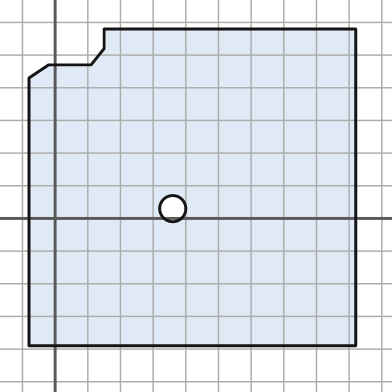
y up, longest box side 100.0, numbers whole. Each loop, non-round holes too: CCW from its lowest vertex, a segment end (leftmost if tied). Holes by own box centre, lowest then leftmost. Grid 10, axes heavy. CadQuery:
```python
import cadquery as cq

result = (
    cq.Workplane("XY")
    .moveTo(-8.0, -39.0)
    .lineTo(92.0, -39.0)
    .lineTo(92.0, 58.0)
    .lineTo(15.0, 58.0)
    .lineTo(15.0, 52.0)
    .lineTo(11.0, 47.0)
    .lineTo(-2.0, 47.0)
    .lineTo(-8.0, 43.0)
    .close()
    .moveTo(36.0, 3.0)
    .circle(4.0)
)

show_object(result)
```